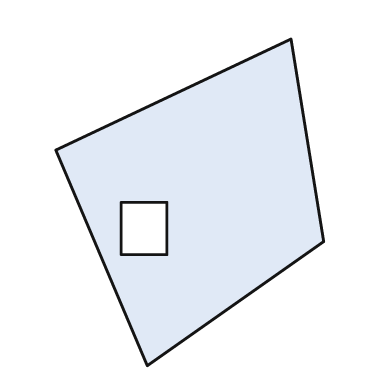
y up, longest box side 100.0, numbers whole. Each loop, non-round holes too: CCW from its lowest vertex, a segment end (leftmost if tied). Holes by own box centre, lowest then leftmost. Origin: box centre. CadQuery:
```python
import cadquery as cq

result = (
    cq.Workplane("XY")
    .moveTo(-13.0, -50.0)
    .lineTo(41.0, -12.0)
    .lineTo(31.0, 50.0)
    .lineTo(-41.0, 16.0)
    .close()
    .moveTo(-21.0, -16.0)
    .lineTo(-7.0, -16.0)
    .lineTo(-7.0, 0.0)
    .lineTo(-21.0, 0.0)
    .close()
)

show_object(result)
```